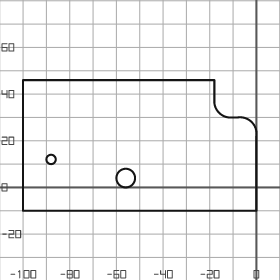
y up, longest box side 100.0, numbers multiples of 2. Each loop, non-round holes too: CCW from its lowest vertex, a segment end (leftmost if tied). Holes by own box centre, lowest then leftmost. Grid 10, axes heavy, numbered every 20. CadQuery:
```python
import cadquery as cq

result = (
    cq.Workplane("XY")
    .moveTo(-100.0, -10.0)
    .lineTo(0.0, -10.0)
    .lineTo(0.0, 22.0)
    .threePointArc((-2.0, 28.0), (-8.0, 30.0))
    .lineTo(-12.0, 30.0)
    .threePointArc((-16.0, 32.0), (-18.0, 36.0))
    .lineTo(-18.0, 46.0)
    .lineTo(-100.0, 46.0)
    .close()
    .moveTo(-56.0, 4.0)
    .circle(4.0)
    .moveTo(-88.0, 12.0)
    .circle(2.0)
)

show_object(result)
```